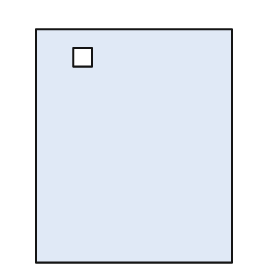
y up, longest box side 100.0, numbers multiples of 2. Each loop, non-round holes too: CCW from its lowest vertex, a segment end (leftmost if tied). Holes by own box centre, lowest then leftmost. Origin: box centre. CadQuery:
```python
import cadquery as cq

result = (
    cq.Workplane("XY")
    .moveTo(-42.0, -50.0)
    .lineTo(42.0, -50.0)
    .lineTo(42.0, 50.0)
    .lineTo(-42.0, 50.0)
    .close()
    .moveTo(-26.0, 34.0)
    .lineTo(-18.0, 34.0)
    .lineTo(-18.0, 42.0)
    .lineTo(-26.0, 42.0)
    .close()
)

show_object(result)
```